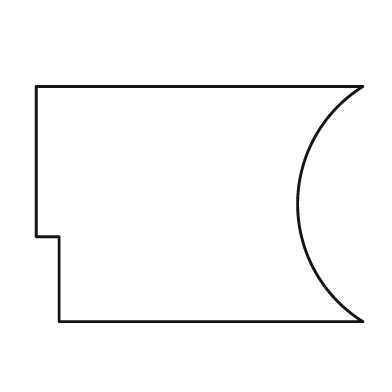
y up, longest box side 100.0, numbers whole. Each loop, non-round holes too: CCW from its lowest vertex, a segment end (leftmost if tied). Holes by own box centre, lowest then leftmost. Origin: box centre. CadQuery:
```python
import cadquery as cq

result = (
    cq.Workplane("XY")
    .moveTo(-43.0, -36.0)
    .lineTo(50.0, -36.0)
    .threePointArc((30.0, 0.0), (50.0, 36.0))
    .lineTo(-50.0, 36.0)
    .lineTo(-50.0, -10.0)
    .lineTo(-43.0, -10.0)
    .close()
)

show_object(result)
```